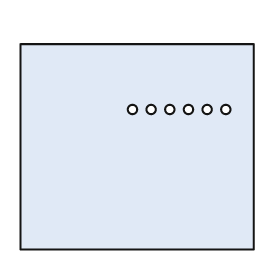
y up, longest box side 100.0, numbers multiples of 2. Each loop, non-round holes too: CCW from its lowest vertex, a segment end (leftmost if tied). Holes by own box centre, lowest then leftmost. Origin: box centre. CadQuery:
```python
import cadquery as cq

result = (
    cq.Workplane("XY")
    .moveTo(-50.0, -44.0)
    .lineTo(50.0, -44.0)
    .lineTo(50.0, 44.0)
    .lineTo(-50.0, 44.0)
    .close()
    .moveTo(-2.0, 16.0)
    .circle(2.0)
    .moveTo(6.0, 16.0)
    .circle(2.0)
    .moveTo(14.0, 16.0)
    .circle(2.0)
    .moveTo(22.0, 16.0)
    .circle(2.0)
    .moveTo(30.0, 16.0)
    .circle(2.0)
    .moveTo(38.0, 16.0)
    .circle(2.0)
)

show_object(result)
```